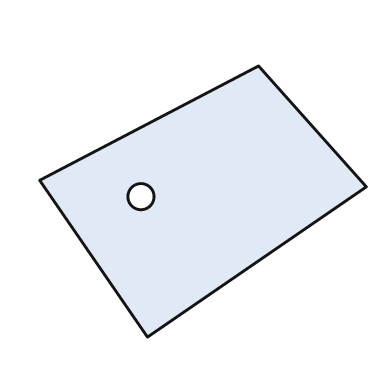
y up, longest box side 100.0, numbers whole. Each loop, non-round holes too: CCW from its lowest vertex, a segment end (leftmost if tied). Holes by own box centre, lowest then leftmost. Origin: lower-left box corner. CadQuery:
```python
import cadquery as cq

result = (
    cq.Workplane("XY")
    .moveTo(33.0, 0.0)
    .lineTo(100.0, 46.0)
    .lineTo(67.0, 83.0)
    .lineTo(0.0, 48.0)
    .close()
    .moveTo(31.0, 43.0)
    .circle(4.0)
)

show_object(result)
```